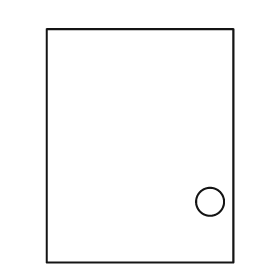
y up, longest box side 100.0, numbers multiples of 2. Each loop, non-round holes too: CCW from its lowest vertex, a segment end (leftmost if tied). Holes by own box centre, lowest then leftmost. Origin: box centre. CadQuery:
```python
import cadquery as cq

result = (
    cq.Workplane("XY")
    .moveTo(-40.0, -50.0)
    .lineTo(40.0, -50.0)
    .lineTo(40.0, 50.0)
    .lineTo(-40.0, 50.0)
    .close()
    .moveTo(30.0, -24.0)
    .circle(6.0)
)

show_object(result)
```